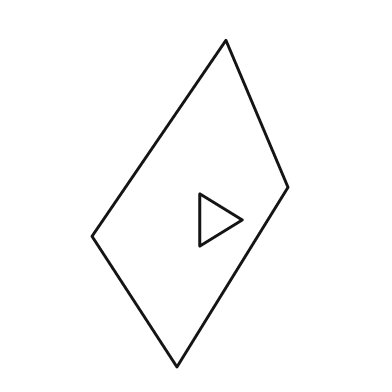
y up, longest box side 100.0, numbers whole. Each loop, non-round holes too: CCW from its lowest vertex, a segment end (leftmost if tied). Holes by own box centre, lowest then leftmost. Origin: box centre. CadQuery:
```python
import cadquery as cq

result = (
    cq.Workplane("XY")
    .moveTo(-4.0, -50.0)
    .lineTo(30.0, 5.0)
    .lineTo(11.0, 50.0)
    .lineTo(-30.0, -10.0)
    .close()
    .moveTo(3.0, -13.0)
    .lineTo(16.0, -5.0)
    .lineTo(3.0, 3.0)
    .close()
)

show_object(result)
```